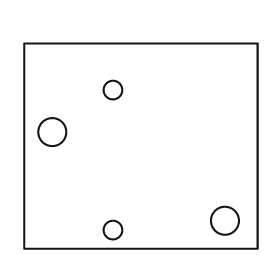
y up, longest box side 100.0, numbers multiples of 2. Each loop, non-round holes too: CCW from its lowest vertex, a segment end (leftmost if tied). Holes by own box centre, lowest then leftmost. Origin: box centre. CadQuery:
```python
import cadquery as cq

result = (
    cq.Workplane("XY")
    .moveTo(-50.0, -44.0)
    .lineTo(50.0, -44.0)
    .lineTo(50.0, 44.0)
    .lineTo(-50.0, 44.0)
    .close()
    .moveTo(-12.0, -36.0)
    .circle(4.0)
    .moveTo(36.0, -32.0)
    .circle(6.0)
    .moveTo(-38.0, 6.0)
    .circle(6.0)
    .moveTo(-12.0, 24.0)
    .circle(4.0)
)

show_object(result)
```